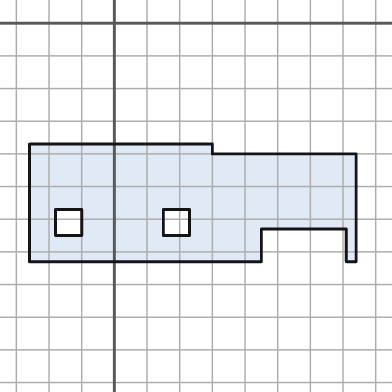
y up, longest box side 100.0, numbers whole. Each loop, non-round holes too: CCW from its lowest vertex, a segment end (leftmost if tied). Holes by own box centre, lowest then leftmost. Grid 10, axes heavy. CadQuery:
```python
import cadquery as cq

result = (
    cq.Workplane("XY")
    .moveTo(-26.0, -73.0)
    .lineTo(45.0, -73.0)
    .lineTo(45.0, -63.0)
    .lineTo(71.0, -63.0)
    .lineTo(71.0, -73.0)
    .lineTo(74.0, -73.0)
    .lineTo(74.0, -40.0)
    .lineTo(30.0, -40.0)
    .lineTo(30.0, -37.0)
    .lineTo(-26.0, -37.0)
    .close()
    .moveTo(-18.0, -65.0)
    .lineTo(-10.0, -65.0)
    .lineTo(-10.0, -57.0)
    .lineTo(-18.0, -57.0)
    .close()
    .moveTo(15.0, -65.0)
    .lineTo(23.0, -65.0)
    .lineTo(23.0, -57.0)
    .lineTo(15.0, -57.0)
    .close()
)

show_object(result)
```